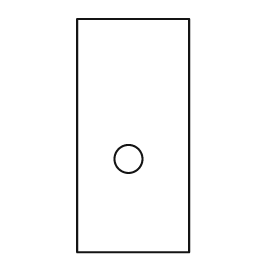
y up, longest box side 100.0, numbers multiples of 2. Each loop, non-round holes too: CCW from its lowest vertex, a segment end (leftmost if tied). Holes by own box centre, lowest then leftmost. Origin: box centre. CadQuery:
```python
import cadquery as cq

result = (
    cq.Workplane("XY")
    .moveTo(-24.0, -50.0)
    .lineTo(24.0, -50.0)
    .lineTo(24.0, 50.0)
    .lineTo(-24.0, 50.0)
    .close()
    .moveTo(-2.0, -10.0)
    .circle(6.0)
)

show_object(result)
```